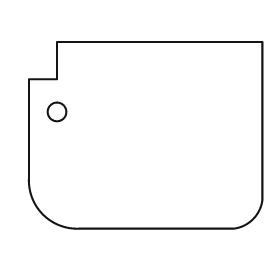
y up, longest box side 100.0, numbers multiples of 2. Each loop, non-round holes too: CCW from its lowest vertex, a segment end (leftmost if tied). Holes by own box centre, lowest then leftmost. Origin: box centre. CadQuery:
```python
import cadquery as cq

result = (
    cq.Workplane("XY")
    .moveTo(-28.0, -40.0)
    .lineTo(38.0, -40.0)
    .threePointArc((46.0, -36.0), (50.0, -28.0))
    .lineTo(50.0, 40.0)
    .lineTo(-38.0, 40.0)
    .lineTo(-38.0, 24.0)
    .lineTo(-50.0, 24.0)
    .lineTo(-50.0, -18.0)
    .threePointArc((-44.0, -34.0), (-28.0, -40.0))
    .close()
    .moveTo(-38.0, 10.0)
    .circle(4.0)
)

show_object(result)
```